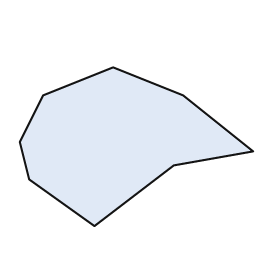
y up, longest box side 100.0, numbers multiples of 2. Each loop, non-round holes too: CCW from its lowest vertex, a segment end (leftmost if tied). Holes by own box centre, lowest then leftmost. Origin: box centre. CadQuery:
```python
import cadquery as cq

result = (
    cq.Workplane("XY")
    .moveTo(-18.0, -34.0)
    .lineTo(16.0, -8.0)
    .lineTo(50.0, -2.0)
    .lineTo(20.0, 22.0)
    .lineTo(-10.0, 34.0)
    .lineTo(-40.0, 22.0)
    .lineTo(-50.0, 2.0)
    .lineTo(-46.0, -14.0)
    .close()
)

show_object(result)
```